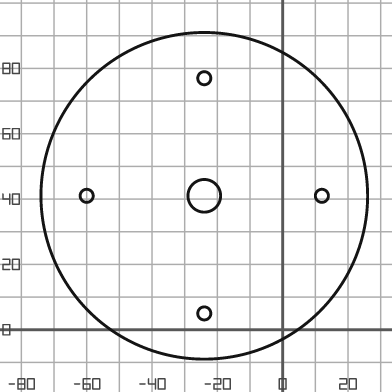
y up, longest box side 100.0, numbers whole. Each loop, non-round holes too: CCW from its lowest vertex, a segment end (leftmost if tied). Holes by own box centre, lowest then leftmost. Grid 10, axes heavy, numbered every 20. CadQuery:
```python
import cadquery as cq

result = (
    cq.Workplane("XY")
    .moveTo(-24.0, 41.0)
    .circle(50.0)
    .moveTo(-24.0, 5.0)
    .circle(2.0)
    .moveTo(-60.0, 41.0)
    .circle(2.0)
    .moveTo(-24.0, 41.0)
    .circle(5.0)
    .moveTo(12.0, 41.0)
    .circle(2.0)
    .moveTo(-24.0, 77.0)
    .circle(2.0)
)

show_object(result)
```